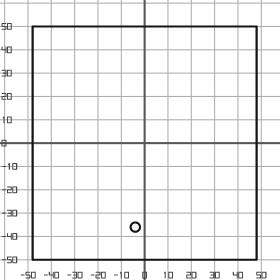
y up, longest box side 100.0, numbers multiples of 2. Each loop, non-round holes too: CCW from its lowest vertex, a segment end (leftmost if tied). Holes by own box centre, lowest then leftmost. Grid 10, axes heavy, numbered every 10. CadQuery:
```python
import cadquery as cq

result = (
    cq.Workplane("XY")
    .moveTo(-48.0, -50.0)
    .lineTo(48.0, -50.0)
    .lineTo(48.0, 50.0)
    .lineTo(-48.0, 50.0)
    .close()
    .moveTo(-4.0, -36.0)
    .circle(2.0)
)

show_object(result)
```